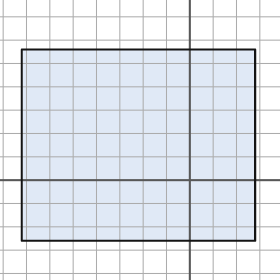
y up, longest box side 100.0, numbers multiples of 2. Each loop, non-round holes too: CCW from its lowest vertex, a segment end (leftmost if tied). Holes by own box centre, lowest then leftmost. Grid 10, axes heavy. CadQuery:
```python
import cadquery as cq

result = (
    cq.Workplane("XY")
    .moveTo(-72.0, -26.0)
    .lineTo(28.0, -26.0)
    .lineTo(28.0, 56.0)
    .lineTo(-72.0, 56.0)
    .close()
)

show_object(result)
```